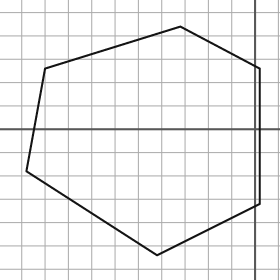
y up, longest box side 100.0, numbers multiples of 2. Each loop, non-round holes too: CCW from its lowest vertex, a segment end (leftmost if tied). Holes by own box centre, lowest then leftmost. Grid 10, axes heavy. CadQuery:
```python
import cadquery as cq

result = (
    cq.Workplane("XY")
    .moveTo(-42.0, -54.0)
    .lineTo(2.0, -32.0)
    .lineTo(2.0, 26.0)
    .lineTo(-32.0, 44.0)
    .lineTo(-90.0, 26.0)
    .lineTo(-98.0, -18.0)
    .close()
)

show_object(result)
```